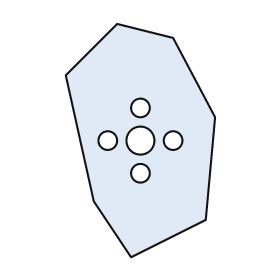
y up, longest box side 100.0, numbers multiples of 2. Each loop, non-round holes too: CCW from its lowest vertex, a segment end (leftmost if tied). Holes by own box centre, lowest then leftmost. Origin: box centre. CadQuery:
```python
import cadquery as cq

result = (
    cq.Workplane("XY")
    .moveTo(-4.0, -50.0)
    .lineTo(28.0, -34.0)
    .lineTo(32.0, 10.0)
    .lineTo(14.0, 44.0)
    .lineTo(-10.0, 50.0)
    .lineTo(-32.0, 28.0)
    .lineTo(-20.0, -26.0)
    .close()
    .moveTo(0.0, -14.0)
    .circle(4.0)
    .moveTo(-14.0, 0.0)
    .circle(4.0)
    .moveTo(0.0, 0.0)
    .circle(6.0)
    .moveTo(14.0, 0.0)
    .circle(4.0)
    .moveTo(0.0, 14.0)
    .circle(4.0)
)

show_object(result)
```